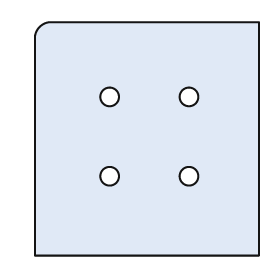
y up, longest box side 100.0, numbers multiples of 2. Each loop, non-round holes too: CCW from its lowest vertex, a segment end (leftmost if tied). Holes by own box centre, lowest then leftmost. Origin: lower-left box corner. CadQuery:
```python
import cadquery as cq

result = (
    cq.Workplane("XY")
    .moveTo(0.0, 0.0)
    .lineTo(96.0, 0.0)
    .lineTo(96.0, 100.0)
    .lineTo(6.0, 100.0)
    .threePointArc((2.0, 98.0), (0.0, 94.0))
    .close()
    .moveTo(32.0, 34.0)
    .circle(4.0)
    .moveTo(66.0, 34.0)
    .circle(4.0)
    .moveTo(32.0, 68.0)
    .circle(4.0)
    .moveTo(66.0, 68.0)
    .circle(4.0)
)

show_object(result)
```